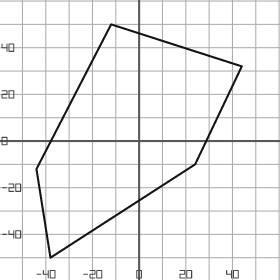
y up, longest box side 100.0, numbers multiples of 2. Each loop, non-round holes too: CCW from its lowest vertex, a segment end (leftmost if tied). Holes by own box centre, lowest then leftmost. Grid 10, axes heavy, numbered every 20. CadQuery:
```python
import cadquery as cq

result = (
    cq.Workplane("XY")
    .moveTo(-38.0, -50.0)
    .lineTo(24.0, -10.0)
    .lineTo(44.0, 32.0)
    .lineTo(-12.0, 50.0)
    .lineTo(-44.0, -12.0)
    .close()
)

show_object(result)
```